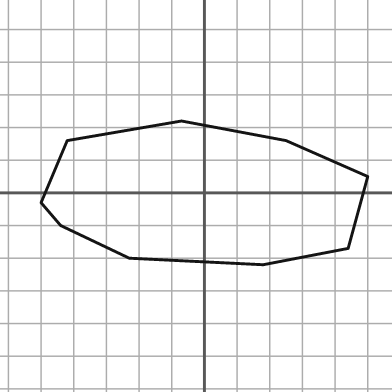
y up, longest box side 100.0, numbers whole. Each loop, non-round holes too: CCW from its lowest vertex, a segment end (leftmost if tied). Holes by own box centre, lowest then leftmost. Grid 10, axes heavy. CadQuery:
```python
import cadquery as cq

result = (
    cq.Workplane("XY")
    .moveTo(18.0, -22.0)
    .lineTo(44.0, -17.0)
    .lineTo(50.0, 5.0)
    .lineTo(25.0, 16.0)
    .lineTo(-7.0, 22.0)
    .lineTo(-42.0, 16.0)
    .lineTo(-50.0, -3.0)
    .lineTo(-44.0, -10.0)
    .lineTo(-23.0, -20.0)
    .close()
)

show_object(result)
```